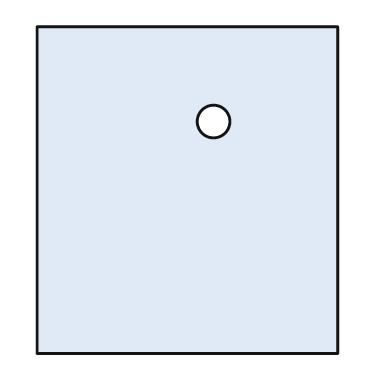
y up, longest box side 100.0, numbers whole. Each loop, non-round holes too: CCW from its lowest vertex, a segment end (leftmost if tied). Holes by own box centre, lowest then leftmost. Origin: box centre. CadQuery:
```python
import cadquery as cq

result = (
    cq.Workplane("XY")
    .moveTo(-46.0, -50.0)
    .lineTo(46.0, -50.0)
    .lineTo(46.0, 50.0)
    .lineTo(-46.0, 50.0)
    .close()
    .moveTo(8.0, 21.0)
    .circle(5.0)
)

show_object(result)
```